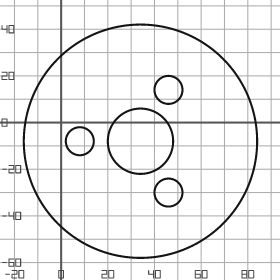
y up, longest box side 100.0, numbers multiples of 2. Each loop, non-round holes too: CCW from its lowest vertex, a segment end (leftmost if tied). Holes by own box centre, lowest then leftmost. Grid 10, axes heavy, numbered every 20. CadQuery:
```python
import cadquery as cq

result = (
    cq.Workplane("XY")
    .moveTo(34.0, -8.0)
    .circle(50.0)
    .moveTo(46.0, -30.0)
    .circle(6.0)
    .moveTo(8.0, -8.0)
    .circle(6.0)
    .moveTo(34.0, -8.0)
    .circle(14.0)
    .moveTo(46.0, 14.0)
    .circle(6.0)
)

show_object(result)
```